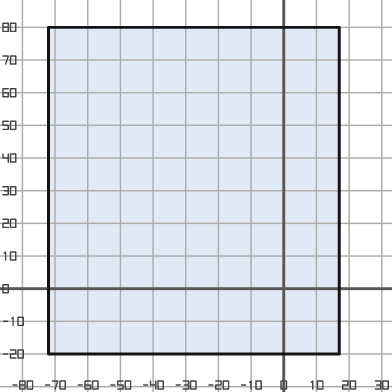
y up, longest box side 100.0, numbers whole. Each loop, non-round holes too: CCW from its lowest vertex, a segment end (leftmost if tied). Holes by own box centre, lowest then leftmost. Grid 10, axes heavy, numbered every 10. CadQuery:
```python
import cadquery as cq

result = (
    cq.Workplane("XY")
    .moveTo(-72.0, -20.0)
    .lineTo(17.0, -20.0)
    .lineTo(17.0, 80.0)
    .lineTo(-72.0, 80.0)
    .close()
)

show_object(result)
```